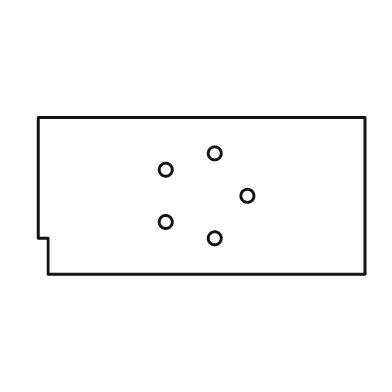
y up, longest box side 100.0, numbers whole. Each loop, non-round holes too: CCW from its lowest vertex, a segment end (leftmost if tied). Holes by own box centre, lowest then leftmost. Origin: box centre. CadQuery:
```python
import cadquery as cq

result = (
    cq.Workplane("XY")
    .moveTo(-47.0, -24.0)
    .lineTo(50.0, -24.0)
    .lineTo(50.0, 24.0)
    .lineTo(-50.0, 24.0)
    .lineTo(-50.0, -13.0)
    .lineTo(-47.0, -13.0)
    .close()
    .moveTo(4.0, -13.0)
    .circle(2.0)
    .moveTo(-11.0, -8.0)
    .circle(2.0)
    .moveTo(14.0, 0.0)
    .circle(2.0)
    .moveTo(-11.0, 8.0)
    .circle(2.0)
    .moveTo(4.0, 13.0)
    .circle(2.0)
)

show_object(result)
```